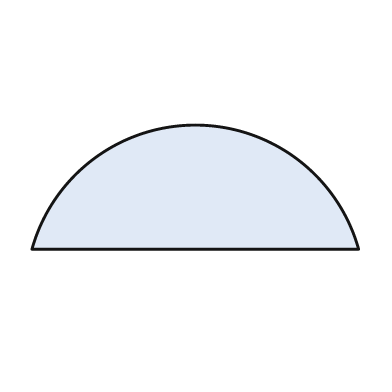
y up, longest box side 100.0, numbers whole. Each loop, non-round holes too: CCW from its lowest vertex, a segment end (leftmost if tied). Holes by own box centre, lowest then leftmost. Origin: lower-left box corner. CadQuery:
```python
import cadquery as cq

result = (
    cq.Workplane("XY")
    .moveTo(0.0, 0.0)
    .lineTo(100.0, 0.0)
    .threePointArc((50.0, 38.0), (0.0, 0.0))
    .close()
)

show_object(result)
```